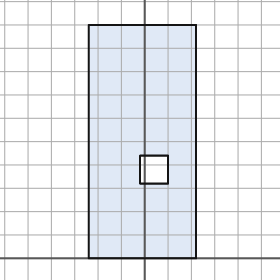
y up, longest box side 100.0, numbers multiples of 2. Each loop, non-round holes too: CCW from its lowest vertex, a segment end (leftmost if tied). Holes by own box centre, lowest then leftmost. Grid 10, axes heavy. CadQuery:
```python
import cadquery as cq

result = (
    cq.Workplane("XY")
    .moveTo(-24.0, 0.0)
    .lineTo(22.0, 0.0)
    .lineTo(22.0, 100.0)
    .lineTo(-24.0, 100.0)
    .close()
    .moveTo(-2.0, 32.0)
    .lineTo(10.0, 32.0)
    .lineTo(10.0, 44.0)
    .lineTo(-2.0, 44.0)
    .close()
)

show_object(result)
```